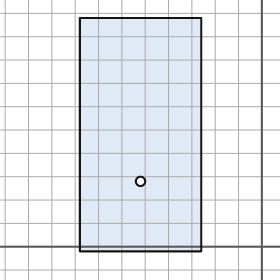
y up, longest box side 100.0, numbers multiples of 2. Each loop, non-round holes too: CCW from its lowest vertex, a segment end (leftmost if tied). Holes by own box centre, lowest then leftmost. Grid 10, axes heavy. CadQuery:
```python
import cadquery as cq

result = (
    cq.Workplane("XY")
    .moveTo(-78.0, -2.0)
    .lineTo(-26.0, -2.0)
    .lineTo(-26.0, 98.0)
    .lineTo(-78.0, 98.0)
    .close()
    .moveTo(-52.0, 28.0)
    .circle(2.0)
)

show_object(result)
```